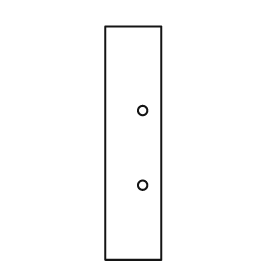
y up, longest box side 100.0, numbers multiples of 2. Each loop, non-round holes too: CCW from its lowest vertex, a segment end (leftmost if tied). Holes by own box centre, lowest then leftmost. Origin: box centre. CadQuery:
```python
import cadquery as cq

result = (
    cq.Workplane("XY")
    .moveTo(-12.0, -50.0)
    .lineTo(12.0, -50.0)
    .lineTo(12.0, 50.0)
    .lineTo(-12.0, 50.0)
    .close()
    .moveTo(4.0, -18.0)
    .circle(2.0)
    .moveTo(4.0, 14.0)
    .circle(2.0)
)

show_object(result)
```